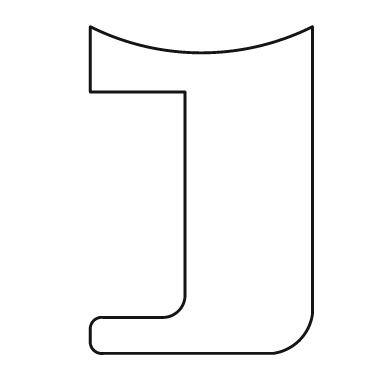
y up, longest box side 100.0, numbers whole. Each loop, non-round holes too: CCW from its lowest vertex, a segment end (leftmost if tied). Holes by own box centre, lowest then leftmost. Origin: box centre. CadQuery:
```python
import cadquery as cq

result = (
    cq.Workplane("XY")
    .moveTo(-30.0, -50.0)
    .lineTo(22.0, -50.0)
    .threePointArc((30.0, -46.0), (34.0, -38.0))
    .lineTo(34.0, 50.0)
    .threePointArc((0.0, 42.0), (-34.0, 50.0))
    .lineTo(-34.0, 30.0)
    .lineTo(-5.0, 30.0)
    .lineTo(-5.0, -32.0)
    .threePointArc((-7.0, -37.0), (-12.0, -39.0))
    .lineTo(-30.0, -39.0)
    .threePointArc((-33.0, -40.0), (-34.0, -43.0))
    .lineTo(-34.0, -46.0)
    .threePointArc((-33.0, -49.0), (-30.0, -50.0))
    .close()
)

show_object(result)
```